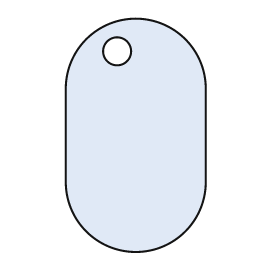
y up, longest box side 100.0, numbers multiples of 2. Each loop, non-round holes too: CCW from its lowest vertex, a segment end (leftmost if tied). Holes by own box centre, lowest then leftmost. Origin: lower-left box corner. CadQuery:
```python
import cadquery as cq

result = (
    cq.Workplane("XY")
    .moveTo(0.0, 30.0)
    .threePointArc((30.0, 0.0), (60.0, 30.0))
    .lineTo(60.0, 70.0)
    .threePointArc((30.0, 100.0), (0.0, 70.0))
    .close()
    .moveTo(22.0, 86.0)
    .circle(6.0)
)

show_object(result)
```